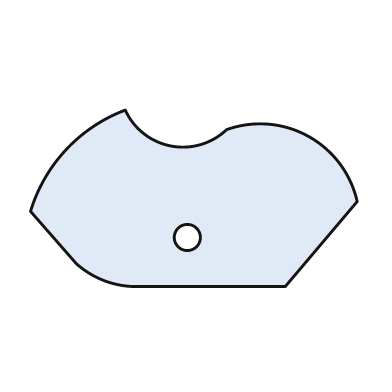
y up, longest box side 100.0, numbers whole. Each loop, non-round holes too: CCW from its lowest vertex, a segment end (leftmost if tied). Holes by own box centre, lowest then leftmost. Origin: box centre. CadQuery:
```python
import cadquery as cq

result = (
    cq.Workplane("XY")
    .moveTo(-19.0, -27.0)
    .lineTo(28.0, -27.0)
    .lineTo(50.0, -1.0)
    .threePointArc((35.0, 19.0), (10.0, 21.0))
    .threePointArc((-7.0, 16.0), (-21.0, 27.0))
    .threePointArc((-39.0, 15.0), (-50.0, -4.0))
    .lineTo(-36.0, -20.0)
    .threePointArc((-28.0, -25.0), (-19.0, -27.0))
    .close()
    .moveTo(-2.0, -12.0)
    .circle(4.0)
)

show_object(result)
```